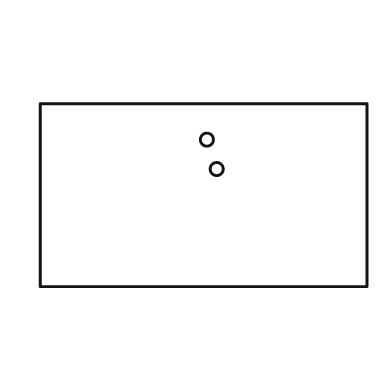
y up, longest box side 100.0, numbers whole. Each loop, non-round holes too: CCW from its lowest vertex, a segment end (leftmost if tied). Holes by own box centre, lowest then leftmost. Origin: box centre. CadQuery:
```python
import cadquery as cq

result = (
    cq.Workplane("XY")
    .moveTo(-50.0, -28.0)
    .lineTo(50.0, -28.0)
    .lineTo(50.0, 28.0)
    .lineTo(-50.0, 28.0)
    .close()
    .moveTo(4.0, 8.0)
    .circle(2.0)
    .moveTo(1.0, 17.0)
    .circle(2.0)
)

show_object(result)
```